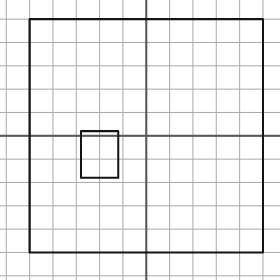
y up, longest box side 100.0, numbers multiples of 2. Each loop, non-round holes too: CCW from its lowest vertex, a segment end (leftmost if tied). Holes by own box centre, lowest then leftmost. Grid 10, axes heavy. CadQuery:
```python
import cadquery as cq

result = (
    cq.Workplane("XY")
    .moveTo(-50.0, -50.0)
    .lineTo(50.0, -50.0)
    .lineTo(50.0, 50.0)
    .lineTo(-50.0, 50.0)
    .close()
    .moveTo(-28.0, -18.0)
    .lineTo(-12.0, -18.0)
    .lineTo(-12.0, 2.0)
    .lineTo(-28.0, 2.0)
    .close()
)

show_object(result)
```